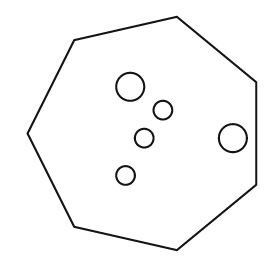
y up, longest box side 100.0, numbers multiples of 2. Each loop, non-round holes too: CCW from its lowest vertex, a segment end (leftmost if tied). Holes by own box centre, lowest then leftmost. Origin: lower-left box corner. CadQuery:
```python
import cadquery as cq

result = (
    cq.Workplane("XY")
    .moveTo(64.0, 0.0)
    .lineTo(98.0, 28.0)
    .lineTo(98.0, 72.0)
    .lineTo(64.0, 100.0)
    .lineTo(20.0, 90.0)
    .lineTo(0.0, 50.0)
    .lineTo(20.0, 10.0)
    .close()
    .moveTo(42.0, 32.0)
    .circle(4.0)
    .moveTo(50.0, 48.0)
    .circle(4.0)
    .moveTo(88.0, 48.0)
    .circle(6.0)
    .moveTo(58.0, 60.0)
    .circle(4.0)
    .moveTo(44.0, 70.0)
    .circle(6.0)
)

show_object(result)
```